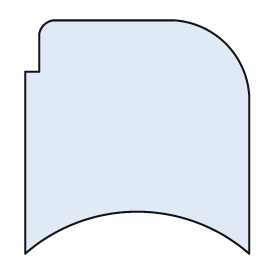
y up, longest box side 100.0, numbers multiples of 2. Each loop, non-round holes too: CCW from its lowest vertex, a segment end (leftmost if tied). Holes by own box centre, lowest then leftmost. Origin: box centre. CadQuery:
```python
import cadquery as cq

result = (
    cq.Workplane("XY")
    .moveTo(-48.0, -50.0)
    .threePointArc((0.0, -32.0), (48.0, -50.0))
    .lineTo(48.0, 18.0)
    .threePointArc((38.0, 40.0), (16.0, 50.0))
    .lineTo(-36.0, 50.0)
    .threePointArc((-40.0, 48.0), (-42.0, 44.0))
    .lineTo(-42.0, 28.0)
    .lineTo(-48.0, 28.0)
    .close()
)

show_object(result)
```